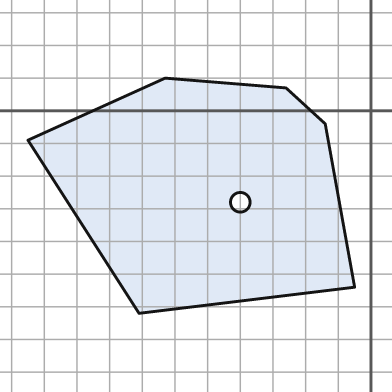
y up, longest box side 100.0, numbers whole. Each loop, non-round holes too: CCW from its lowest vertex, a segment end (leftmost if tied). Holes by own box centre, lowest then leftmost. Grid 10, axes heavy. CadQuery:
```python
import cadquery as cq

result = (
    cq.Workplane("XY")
    .moveTo(-71.0, -62.0)
    .lineTo(-5.0, -54.0)
    .lineTo(-14.0, -4.0)
    .lineTo(-26.0, 7.0)
    .lineTo(-63.0, 10.0)
    .lineTo(-105.0, -9.0)
    .close()
    .moveTo(-40.0, -28.0)
    .circle(3.0)
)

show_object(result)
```